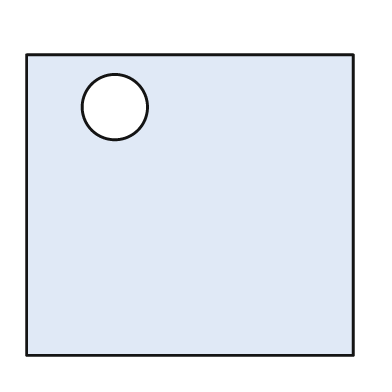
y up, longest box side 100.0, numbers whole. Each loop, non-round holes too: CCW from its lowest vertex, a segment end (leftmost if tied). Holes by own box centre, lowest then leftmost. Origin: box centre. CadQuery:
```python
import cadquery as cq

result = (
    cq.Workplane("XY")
    .moveTo(-50.0, -46.0)
    .lineTo(50.0, -46.0)
    .lineTo(50.0, 46.0)
    .lineTo(-50.0, 46.0)
    .close()
    .moveTo(-23.0, 30.0)
    .circle(10.0)
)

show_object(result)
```